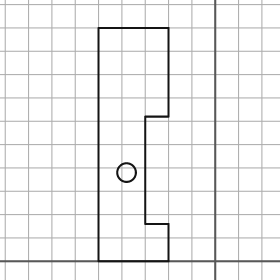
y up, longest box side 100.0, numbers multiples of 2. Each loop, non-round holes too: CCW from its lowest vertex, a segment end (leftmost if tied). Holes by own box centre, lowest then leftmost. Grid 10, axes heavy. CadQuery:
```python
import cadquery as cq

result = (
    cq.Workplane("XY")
    .moveTo(-50.0, 0.0)
    .lineTo(-20.0, 0.0)
    .lineTo(-20.0, 16.0)
    .lineTo(-30.0, 16.0)
    .lineTo(-30.0, 62.0)
    .lineTo(-20.0, 62.0)
    .lineTo(-20.0, 100.0)
    .lineTo(-50.0, 100.0)
    .close()
    .moveTo(-38.0, 38.0)
    .circle(4.0)
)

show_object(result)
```